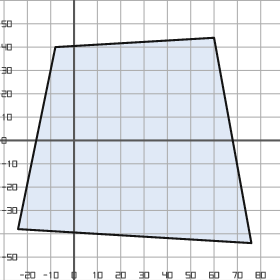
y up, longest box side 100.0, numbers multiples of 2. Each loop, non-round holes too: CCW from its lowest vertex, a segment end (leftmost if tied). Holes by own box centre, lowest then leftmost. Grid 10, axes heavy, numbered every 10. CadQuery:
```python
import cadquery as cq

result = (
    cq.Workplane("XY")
    .moveTo(76.0, -44.0)
    .lineTo(60.0, 44.0)
    .lineTo(-8.0, 40.0)
    .lineTo(-24.0, -38.0)
    .close()
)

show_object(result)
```